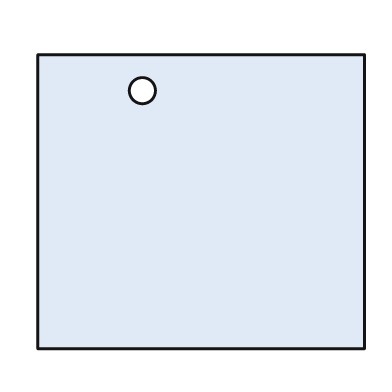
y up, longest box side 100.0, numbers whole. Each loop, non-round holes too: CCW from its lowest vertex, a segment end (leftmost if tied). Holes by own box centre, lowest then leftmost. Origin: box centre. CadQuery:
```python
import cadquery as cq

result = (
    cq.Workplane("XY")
    .moveTo(-50.0, -45.0)
    .lineTo(50.0, -45.0)
    .lineTo(50.0, 45.0)
    .lineTo(-50.0, 45.0)
    .close()
    .moveTo(-18.0, 34.0)
    .circle(4.0)
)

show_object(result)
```